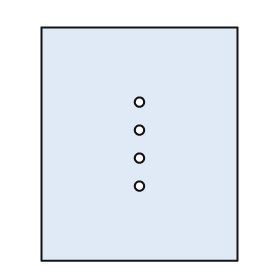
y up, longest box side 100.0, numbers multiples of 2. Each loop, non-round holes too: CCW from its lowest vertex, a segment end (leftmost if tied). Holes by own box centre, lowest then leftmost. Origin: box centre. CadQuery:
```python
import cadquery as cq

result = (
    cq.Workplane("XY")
    .moveTo(-42.0, -50.0)
    .lineTo(42.0, -50.0)
    .lineTo(42.0, 50.0)
    .lineTo(-42.0, 50.0)
    .close()
    .moveTo(0.0, -18.0)
    .circle(2.0)
    .moveTo(0.0, -6.0)
    .circle(2.0)
    .moveTo(0.0, 6.0)
    .circle(2.0)
    .moveTo(0.0, 18.0)
    .circle(2.0)
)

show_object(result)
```